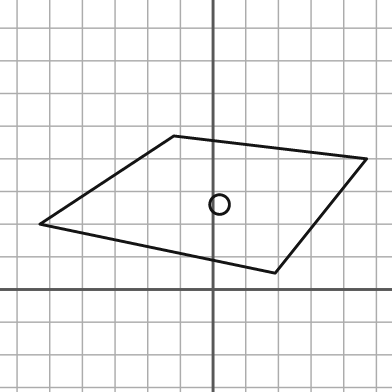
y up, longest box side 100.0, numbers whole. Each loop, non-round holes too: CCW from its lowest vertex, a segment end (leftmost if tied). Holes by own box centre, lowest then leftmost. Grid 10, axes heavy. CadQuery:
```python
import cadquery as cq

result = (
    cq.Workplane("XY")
    .moveTo(19.0, 5.0)
    .lineTo(47.0, 40.0)
    .lineTo(-12.0, 47.0)
    .lineTo(-53.0, 20.0)
    .close()
    .moveTo(2.0, 26.0)
    .circle(3.0)
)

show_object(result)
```